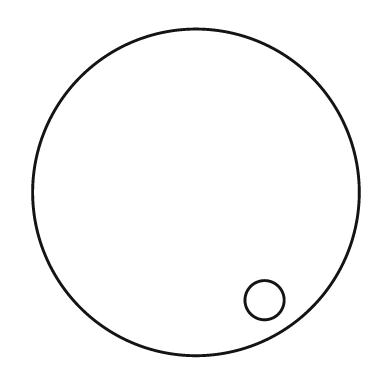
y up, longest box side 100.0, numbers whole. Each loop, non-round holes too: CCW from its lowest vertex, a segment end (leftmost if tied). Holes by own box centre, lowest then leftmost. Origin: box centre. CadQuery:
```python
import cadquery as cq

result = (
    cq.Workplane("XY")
    .moveTo(0.0, 0.0)
    .circle(50.0)
    .moveTo(21.0, -33.0)
    .circle(6.0)
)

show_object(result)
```